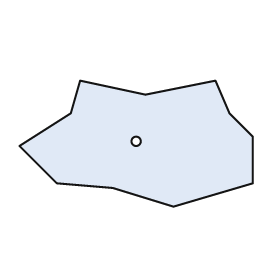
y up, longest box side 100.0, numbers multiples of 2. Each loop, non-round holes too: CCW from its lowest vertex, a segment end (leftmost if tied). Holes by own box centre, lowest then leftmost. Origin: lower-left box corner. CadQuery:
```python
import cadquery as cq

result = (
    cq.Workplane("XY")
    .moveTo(66.0, 0.0)
    .lineTo(100.0, 10.0)
    .lineTo(100.0, 30.0)
    .lineTo(90.0, 40.0)
    .lineTo(84.0, 54.0)
    .lineTo(54.0, 48.0)
    .lineTo(26.0, 54.0)
    .lineTo(22.0, 40.0)
    .lineTo(0.0, 26.0)
    .lineTo(16.0, 10.0)
    .lineTo(40.0, 8.0)
    .close()
    .moveTo(50.0, 28.0)
    .circle(2.0)
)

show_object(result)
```